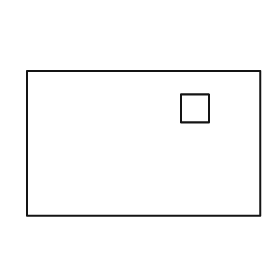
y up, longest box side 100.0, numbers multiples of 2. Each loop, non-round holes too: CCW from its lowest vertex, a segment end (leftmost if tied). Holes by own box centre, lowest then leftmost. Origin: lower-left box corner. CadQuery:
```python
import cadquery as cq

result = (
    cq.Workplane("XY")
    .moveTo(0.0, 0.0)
    .lineTo(100.0, 0.0)
    .lineTo(100.0, 62.0)
    .lineTo(0.0, 62.0)
    .close()
    .moveTo(66.0, 40.0)
    .lineTo(78.0, 40.0)
    .lineTo(78.0, 52.0)
    .lineTo(66.0, 52.0)
    .close()
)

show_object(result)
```